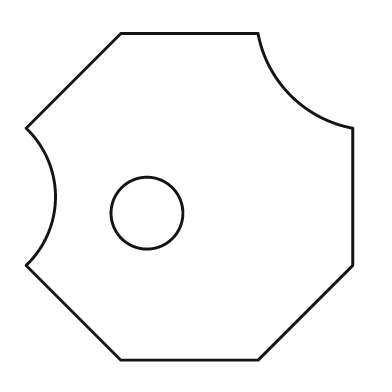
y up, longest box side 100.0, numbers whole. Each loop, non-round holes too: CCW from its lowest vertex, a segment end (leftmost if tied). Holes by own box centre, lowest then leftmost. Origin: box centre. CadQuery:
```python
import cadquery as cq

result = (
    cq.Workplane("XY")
    .moveTo(-21.0, -50.0)
    .lineTo(21.0, -50.0)
    .lineTo(50.0, -21.0)
    .lineTo(50.0, 21.0)
    .threePointArc((31.0, 31.0), (21.0, 50.0))
    .lineTo(-21.0, 50.0)
    .lineTo(-50.0, 21.0)
    .threePointArc((-41.0, 0.0), (-50.0, -21.0))
    .close()
    .moveTo(-13.0, -5.0)
    .circle(11.0)
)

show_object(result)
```